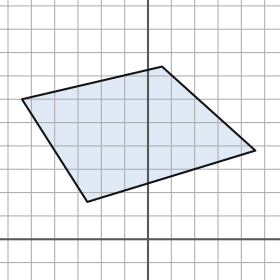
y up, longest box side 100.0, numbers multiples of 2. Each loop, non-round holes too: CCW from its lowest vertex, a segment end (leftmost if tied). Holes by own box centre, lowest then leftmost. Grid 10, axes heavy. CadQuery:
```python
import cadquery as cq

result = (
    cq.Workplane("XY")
    .moveTo(-26.0, 16.0)
    .lineTo(46.0, 38.0)
    .lineTo(6.0, 74.0)
    .lineTo(-54.0, 60.0)
    .close()
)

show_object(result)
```